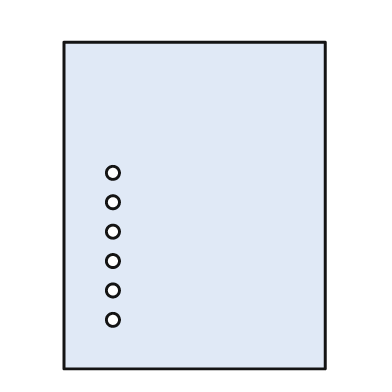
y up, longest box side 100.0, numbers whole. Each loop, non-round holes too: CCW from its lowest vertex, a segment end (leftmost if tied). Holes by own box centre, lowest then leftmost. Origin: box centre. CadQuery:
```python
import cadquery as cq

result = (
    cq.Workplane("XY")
    .moveTo(-40.0, -50.0)
    .lineTo(40.0, -50.0)
    .lineTo(40.0, 50.0)
    .lineTo(-40.0, 50.0)
    .close()
    .moveTo(-25.0, -35.0)
    .circle(2.0)
    .moveTo(-25.0, -26.0)
    .circle(2.0)
    .moveTo(-25.0, -17.0)
    .circle(2.0)
    .moveTo(-25.0, -8.0)
    .circle(2.0)
    .moveTo(-25.0, 1.0)
    .circle(2.0)
    .moveTo(-25.0, 10.0)
    .circle(2.0)
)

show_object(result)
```